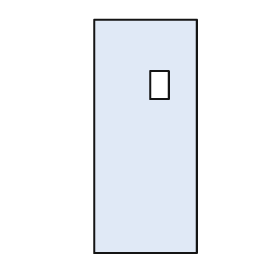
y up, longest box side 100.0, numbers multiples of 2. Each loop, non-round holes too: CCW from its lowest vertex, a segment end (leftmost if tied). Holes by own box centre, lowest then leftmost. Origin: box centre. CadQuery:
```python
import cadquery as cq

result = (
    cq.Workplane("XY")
    .moveTo(-22.0, -50.0)
    .lineTo(22.0, -50.0)
    .lineTo(22.0, 50.0)
    .lineTo(-22.0, 50.0)
    .close()
    .moveTo(2.0, 16.0)
    .lineTo(10.0, 16.0)
    .lineTo(10.0, 28.0)
    .lineTo(2.0, 28.0)
    .close()
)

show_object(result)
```